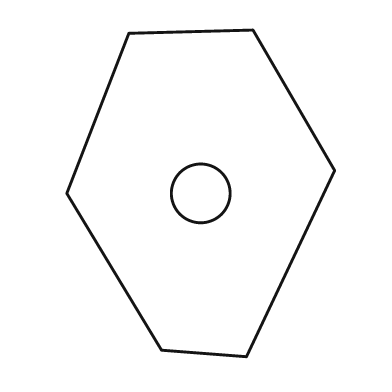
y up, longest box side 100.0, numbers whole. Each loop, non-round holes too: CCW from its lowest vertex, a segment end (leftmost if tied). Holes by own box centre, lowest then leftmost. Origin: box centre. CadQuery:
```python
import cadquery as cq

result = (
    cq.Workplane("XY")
    .moveTo(14.0, -50.0)
    .lineTo(41.0, 7.0)
    .lineTo(16.0, 50.0)
    .lineTo(-22.0, 49.0)
    .lineTo(-41.0, 0.0)
    .lineTo(-12.0, -48.0)
    .close()
    .moveTo(0.0, 0.0)
    .circle(9.0)
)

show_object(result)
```